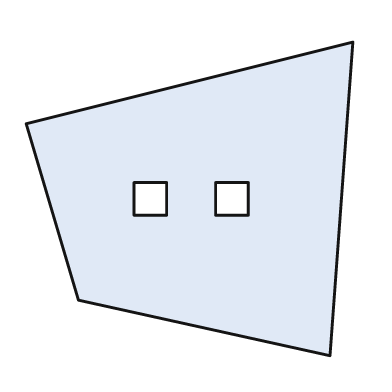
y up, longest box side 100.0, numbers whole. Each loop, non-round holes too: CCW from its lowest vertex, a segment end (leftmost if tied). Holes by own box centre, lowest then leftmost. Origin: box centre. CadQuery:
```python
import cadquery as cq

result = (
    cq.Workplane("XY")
    .moveTo(43.0, -48.0)
    .lineTo(50.0, 48.0)
    .lineTo(-50.0, 23.0)
    .lineTo(-34.0, -31.0)
    .close()
    .moveTo(-17.0, -5.0)
    .lineTo(-7.0, -5.0)
    .lineTo(-7.0, 5.0)
    .lineTo(-17.0, 5.0)
    .close()
    .moveTo(8.0, -5.0)
    .lineTo(18.0, -5.0)
    .lineTo(18.0, 5.0)
    .lineTo(8.0, 5.0)
    .close()
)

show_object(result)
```